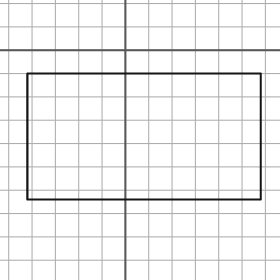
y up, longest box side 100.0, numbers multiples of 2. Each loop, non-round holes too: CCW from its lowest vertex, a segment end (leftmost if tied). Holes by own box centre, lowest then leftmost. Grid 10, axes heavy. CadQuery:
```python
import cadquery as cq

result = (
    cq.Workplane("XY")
    .moveTo(-42.0, -64.0)
    .lineTo(58.0, -64.0)
    .lineTo(58.0, -10.0)
    .lineTo(-42.0, -10.0)
    .close()
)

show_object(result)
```